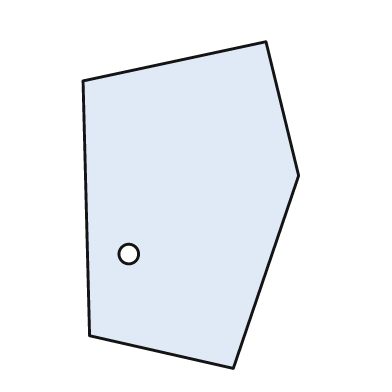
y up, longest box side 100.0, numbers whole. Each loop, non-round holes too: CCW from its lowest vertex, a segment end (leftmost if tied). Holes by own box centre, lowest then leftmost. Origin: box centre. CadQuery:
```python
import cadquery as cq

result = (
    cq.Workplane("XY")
    .moveTo(13.0, -50.0)
    .lineTo(33.0, 9.0)
    .lineTo(23.0, 50.0)
    .lineTo(-33.0, 38.0)
    .lineTo(-31.0, -40.0)
    .close()
    .moveTo(-19.0, -15.0)
    .circle(3.0)
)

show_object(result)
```